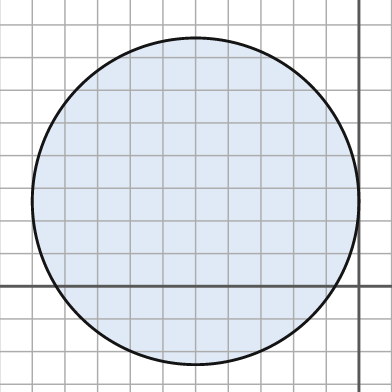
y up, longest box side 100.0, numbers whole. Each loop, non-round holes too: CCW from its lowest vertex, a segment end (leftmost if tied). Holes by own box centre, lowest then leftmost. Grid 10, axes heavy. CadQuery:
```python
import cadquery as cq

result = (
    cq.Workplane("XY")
    .moveTo(-50.0, 26.0)
    .circle(50.0)
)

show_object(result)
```